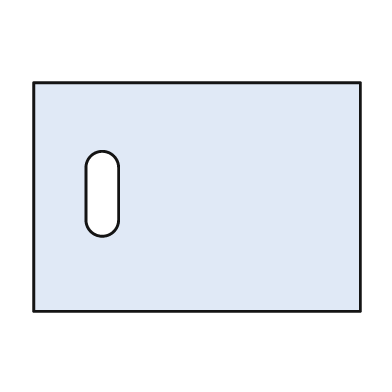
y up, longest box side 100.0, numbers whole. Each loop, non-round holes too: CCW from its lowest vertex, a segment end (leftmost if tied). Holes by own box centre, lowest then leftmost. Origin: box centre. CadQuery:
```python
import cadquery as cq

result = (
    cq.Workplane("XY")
    .moveTo(-50.0, -35.0)
    .lineTo(50.0, -35.0)
    .lineTo(50.0, 35.0)
    .lineTo(-50.0, 35.0)
    .close()
    .moveTo(-34.0, -7.0)
    .threePointArc((-29.0, -12.0), (-24.0, -7.0))
    .lineTo(-24.0, 9.0)
    .threePointArc((-29.0, 14.0), (-34.0, 9.0))
    .close()
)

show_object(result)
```